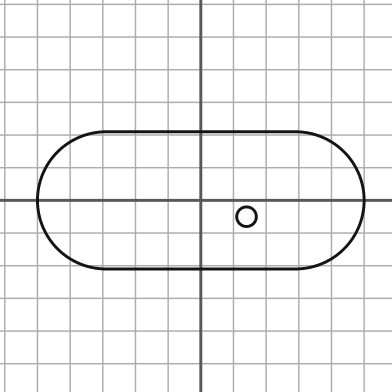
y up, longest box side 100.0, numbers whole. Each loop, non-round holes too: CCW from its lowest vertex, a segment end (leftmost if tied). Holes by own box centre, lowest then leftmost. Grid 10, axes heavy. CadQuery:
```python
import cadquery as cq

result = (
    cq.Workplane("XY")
    .moveTo(-29.0, -21.0)
    .lineTo(29.0, -21.0)
    .threePointArc((50.0, 0.0), (29.0, 21.0))
    .lineTo(-29.0, 21.0)
    .threePointArc((-50.0, 0.0), (-29.0, -21.0))
    .close()
    .moveTo(14.0, -5.0)
    .circle(3.0)
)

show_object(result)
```